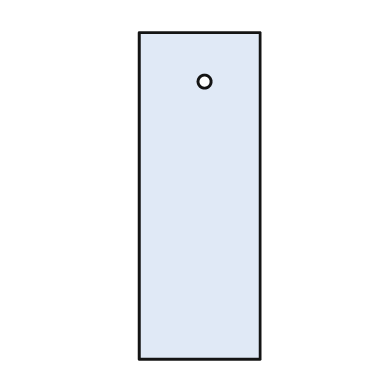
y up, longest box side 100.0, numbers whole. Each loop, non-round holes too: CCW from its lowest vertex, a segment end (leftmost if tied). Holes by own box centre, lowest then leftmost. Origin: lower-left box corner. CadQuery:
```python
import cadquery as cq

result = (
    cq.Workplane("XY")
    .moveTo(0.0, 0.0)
    .lineTo(37.0, 0.0)
    .lineTo(37.0, 100.0)
    .lineTo(0.0, 100.0)
    .close()
    .moveTo(20.0, 85.0)
    .circle(2.0)
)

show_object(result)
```